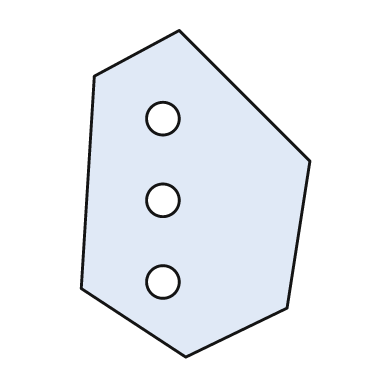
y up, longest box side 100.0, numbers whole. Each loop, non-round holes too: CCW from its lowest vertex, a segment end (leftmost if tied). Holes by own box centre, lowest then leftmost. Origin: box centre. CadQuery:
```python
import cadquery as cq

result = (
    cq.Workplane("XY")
    .moveTo(-3.0, -50.0)
    .lineTo(28.0, -35.0)
    .lineTo(35.0, 10.0)
    .lineTo(-5.0, 50.0)
    .lineTo(-31.0, 36.0)
    .lineTo(-35.0, -29.0)
    .close()
    .moveTo(-10.0, -27.0)
    .circle(5.0)
    .moveTo(-10.0, -2.0)
    .circle(5.0)
    .moveTo(-10.0, 23.0)
    .circle(5.0)
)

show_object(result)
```